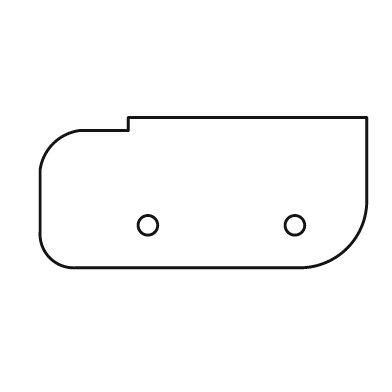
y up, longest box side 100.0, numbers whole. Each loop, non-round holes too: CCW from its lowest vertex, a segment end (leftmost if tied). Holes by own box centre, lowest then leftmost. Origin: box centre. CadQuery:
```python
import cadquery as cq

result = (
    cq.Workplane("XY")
    .moveTo(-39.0, -23.0)
    .lineTo(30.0, -23.0)
    .threePointArc((44.0, -17.0), (50.0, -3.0))
    .lineTo(50.0, 23.0)
    .lineTo(-23.0, 23.0)
    .lineTo(-23.0, 19.0)
    .lineTo(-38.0, 19.0)
    .threePointArc((-46.0, 15.0), (-50.0, 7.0))
    .lineTo(-50.0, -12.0)
    .threePointArc((-47.0, -20.0), (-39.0, -23.0))
    .close()
    .moveTo(-17.0, -10.0)
    .circle(3.0)
    .moveTo(28.0, -10.0)
    .circle(3.0)
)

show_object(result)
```